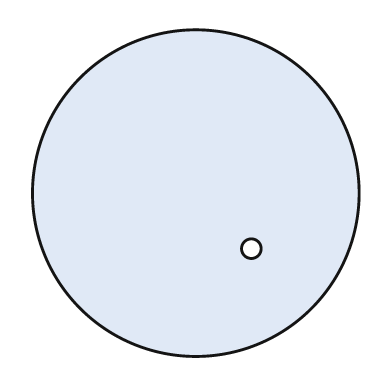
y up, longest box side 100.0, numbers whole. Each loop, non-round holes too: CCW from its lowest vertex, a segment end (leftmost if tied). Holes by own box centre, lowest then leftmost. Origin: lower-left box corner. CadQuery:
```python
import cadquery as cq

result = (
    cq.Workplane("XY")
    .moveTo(50.0, 50.0)
    .circle(50.0)
    .moveTo(67.0, 33.0)
    .circle(3.0)
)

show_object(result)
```